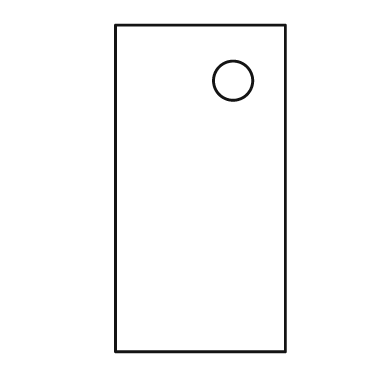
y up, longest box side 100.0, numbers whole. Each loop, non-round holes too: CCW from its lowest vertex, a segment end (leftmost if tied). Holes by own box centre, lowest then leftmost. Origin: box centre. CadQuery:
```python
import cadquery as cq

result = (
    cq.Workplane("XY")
    .moveTo(-26.0, -50.0)
    .lineTo(26.0, -50.0)
    .lineTo(26.0, 50.0)
    .lineTo(-26.0, 50.0)
    .close()
    .moveTo(10.0, 33.0)
    .circle(6.0)
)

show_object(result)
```